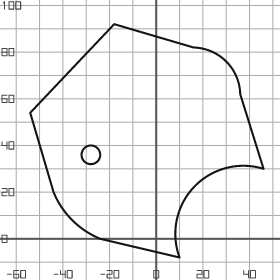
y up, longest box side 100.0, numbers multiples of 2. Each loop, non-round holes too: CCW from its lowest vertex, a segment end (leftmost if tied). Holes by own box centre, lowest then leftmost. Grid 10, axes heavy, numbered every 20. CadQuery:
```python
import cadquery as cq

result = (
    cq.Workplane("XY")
    .moveTo(10.0, -8.0)
    .threePointArc((16.0, 22.0), (46.0, 30.0))
    .lineTo(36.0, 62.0)
    .threePointArc((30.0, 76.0), (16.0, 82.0))
    .lineTo(-18.0, 92.0)
    .lineTo(-54.0, 54.0)
    .lineTo(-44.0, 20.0)
    .threePointArc((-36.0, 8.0), (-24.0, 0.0))
    .close()
    .moveTo(-28.0, 36.0)
    .circle(4.0)
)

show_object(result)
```